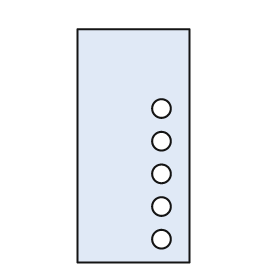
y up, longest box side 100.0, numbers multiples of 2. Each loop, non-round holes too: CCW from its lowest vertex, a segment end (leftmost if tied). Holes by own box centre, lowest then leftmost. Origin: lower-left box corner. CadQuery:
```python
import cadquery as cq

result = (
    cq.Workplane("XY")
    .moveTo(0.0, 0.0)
    .lineTo(48.0, 0.0)
    .lineTo(48.0, 100.0)
    .lineTo(0.0, 100.0)
    .close()
    .moveTo(36.0, 10.0)
    .circle(4.0)
    .moveTo(36.0, 24.0)
    .circle(4.0)
    .moveTo(36.0, 38.0)
    .circle(4.0)
    .moveTo(36.0, 52.0)
    .circle(4.0)
    .moveTo(36.0, 66.0)
    .circle(4.0)
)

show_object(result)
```